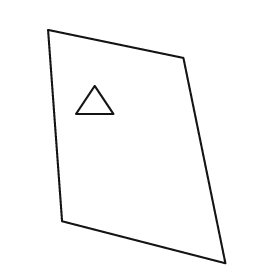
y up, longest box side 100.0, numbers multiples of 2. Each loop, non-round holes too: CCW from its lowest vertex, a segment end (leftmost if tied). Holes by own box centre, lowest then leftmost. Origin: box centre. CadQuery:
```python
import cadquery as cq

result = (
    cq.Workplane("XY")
    .moveTo(38.0, -50.0)
    .lineTo(20.0, 38.0)
    .lineTo(-38.0, 50.0)
    .lineTo(-32.0, -32.0)
    .close()
    .moveTo(-26.0, 14.0)
    .lineTo(-10.0, 14.0)
    .lineTo(-18.0, 26.0)
    .close()
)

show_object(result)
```